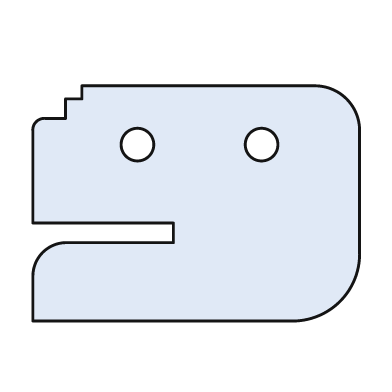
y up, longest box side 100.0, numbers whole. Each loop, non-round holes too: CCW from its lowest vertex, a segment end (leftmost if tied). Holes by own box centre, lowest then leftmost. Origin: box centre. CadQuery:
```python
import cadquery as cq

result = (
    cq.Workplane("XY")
    .moveTo(-50.0, -36.0)
    .lineTo(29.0, -36.0)
    .threePointArc((44.0, -30.0), (50.0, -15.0))
    .lineTo(50.0, 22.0)
    .threePointArc((46.0, 32.0), (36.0, 36.0))
    .lineTo(-35.0, 36.0)
    .lineTo(-35.0, 32.0)
    .lineTo(-40.0, 32.0)
    .lineTo(-40.0, 26.0)
    .lineTo(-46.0, 26.0)
    .threePointArc((-49.0, 25.0), (-50.0, 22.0))
    .lineTo(-50.0, -6.0)
    .lineTo(-7.0, -6.0)
    .lineTo(-7.0, -12.0)
    .lineTo(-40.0, -12.0)
    .threePointArc((-47.0, -15.0), (-50.0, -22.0))
    .close()
    .moveTo(-18.0, 18.0)
    .circle(5.0)
    .moveTo(20.0, 18.0)
    .circle(5.0)
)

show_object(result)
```